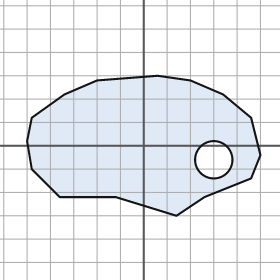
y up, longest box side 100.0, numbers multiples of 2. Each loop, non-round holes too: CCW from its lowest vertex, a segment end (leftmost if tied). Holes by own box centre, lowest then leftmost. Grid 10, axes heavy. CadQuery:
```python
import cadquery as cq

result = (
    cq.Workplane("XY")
    .moveTo(14.0, -30.0)
    .lineTo(26.0, -22.0)
    .lineTo(46.0, -14.0)
    .lineTo(50.0, -4.0)
    .lineTo(46.0, 12.0)
    .lineTo(34.0, 22.0)
    .lineTo(20.0, 28.0)
    .lineTo(6.0, 30.0)
    .lineTo(-20.0, 28.0)
    .lineTo(-34.0, 22.0)
    .lineTo(-48.0, 12.0)
    .lineTo(-50.0, 2.0)
    .lineTo(-48.0, -10.0)
    .lineTo(-36.0, -22.0)
    .lineTo(-12.0, -22.0)
    .close()
    .moveTo(30.0, -6.0)
    .circle(8.0)
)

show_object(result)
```